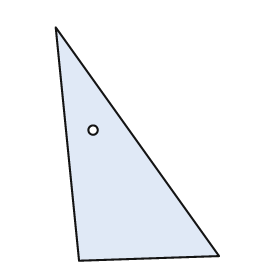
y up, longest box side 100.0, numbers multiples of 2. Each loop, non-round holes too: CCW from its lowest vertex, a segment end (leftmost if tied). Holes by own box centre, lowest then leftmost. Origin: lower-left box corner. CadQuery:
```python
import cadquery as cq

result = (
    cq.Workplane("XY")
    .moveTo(10.0, 0.0)
    .lineTo(70.0, 2.0)
    .lineTo(0.0, 100.0)
    .close()
    .moveTo(16.0, 56.0)
    .circle(2.0)
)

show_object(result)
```